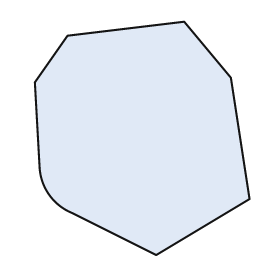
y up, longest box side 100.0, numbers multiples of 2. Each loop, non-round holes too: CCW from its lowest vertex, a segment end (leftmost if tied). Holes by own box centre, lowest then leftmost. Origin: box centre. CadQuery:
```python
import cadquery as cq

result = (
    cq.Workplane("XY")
    .moveTo(6.0, -50.0)
    .lineTo(46.0, -26.0)
    .lineTo(38.0, 26.0)
    .lineTo(18.0, 50.0)
    .lineTo(-32.0, 44.0)
    .lineTo(-46.0, 24.0)
    .lineTo(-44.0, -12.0)
    .threePointArc((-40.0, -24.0), (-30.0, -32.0))
    .close()
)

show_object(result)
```